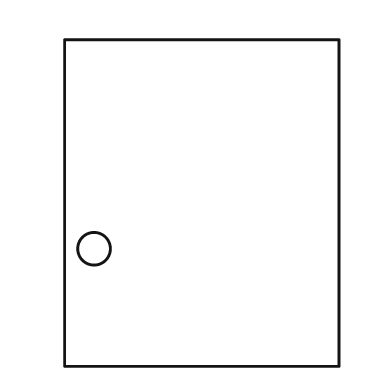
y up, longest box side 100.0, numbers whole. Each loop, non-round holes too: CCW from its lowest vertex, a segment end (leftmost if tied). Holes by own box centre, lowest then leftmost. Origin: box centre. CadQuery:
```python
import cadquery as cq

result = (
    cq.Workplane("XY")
    .moveTo(-42.0, -50.0)
    .lineTo(42.0, -50.0)
    .lineTo(42.0, 50.0)
    .lineTo(-42.0, 50.0)
    .close()
    .moveTo(-33.0, -14.0)
    .circle(5.0)
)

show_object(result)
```